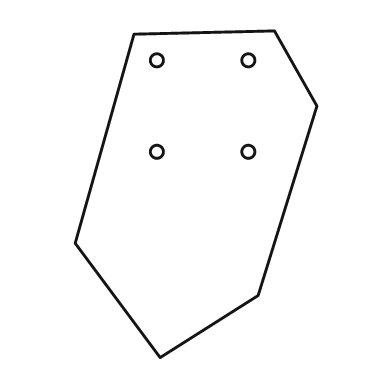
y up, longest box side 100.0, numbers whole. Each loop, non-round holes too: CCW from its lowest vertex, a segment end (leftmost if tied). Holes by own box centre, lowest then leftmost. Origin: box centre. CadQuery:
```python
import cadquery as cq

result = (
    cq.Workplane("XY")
    .moveTo(-11.0, -50.0)
    .lineTo(19.0, -31.0)
    .lineTo(37.0, 27.0)
    .lineTo(24.0, 50.0)
    .lineTo(-19.0, 49.0)
    .lineTo(-37.0, -15.0)
    .close()
    .moveTo(-12.0, 13.0)
    .circle(2.0)
    .moveTo(16.0, 13.0)
    .circle(2.0)
    .moveTo(-12.0, 41.0)
    .circle(2.0)
    .moveTo(16.0, 41.0)
    .circle(2.0)
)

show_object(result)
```